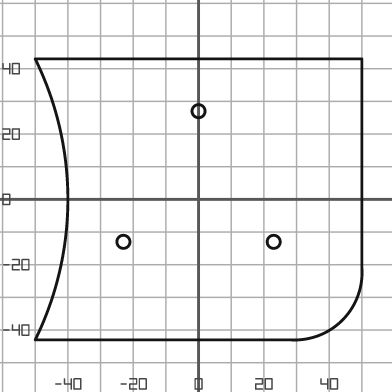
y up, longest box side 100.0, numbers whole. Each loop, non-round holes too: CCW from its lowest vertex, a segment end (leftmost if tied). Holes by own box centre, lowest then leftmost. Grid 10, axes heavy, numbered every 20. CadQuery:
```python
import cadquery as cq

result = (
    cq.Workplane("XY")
    .moveTo(-50.0, -43.0)
    .lineTo(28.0, -43.0)
    .threePointArc((44.0, -37.0), (50.0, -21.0))
    .lineTo(50.0, 43.0)
    .lineTo(-50.0, 43.0)
    .threePointArc((-40.0, 0.0), (-50.0, -43.0))
    .close()
    .moveTo(-23.0, -13.0)
    .circle(2.0)
    .moveTo(23.0, -13.0)
    .circle(2.0)
    .moveTo(0.0, 27.0)
    .circle(2.0)
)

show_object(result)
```